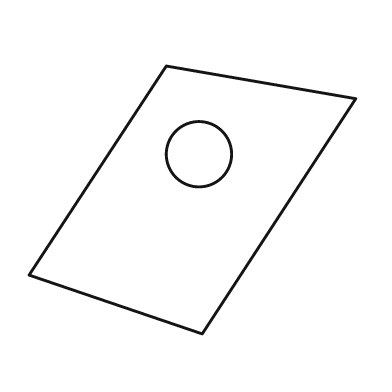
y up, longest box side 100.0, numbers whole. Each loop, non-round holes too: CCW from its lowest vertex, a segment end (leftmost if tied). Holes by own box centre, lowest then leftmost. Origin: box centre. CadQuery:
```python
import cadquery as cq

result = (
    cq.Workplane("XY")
    .moveTo(3.0, -41.0)
    .lineTo(50.0, 31.0)
    .lineTo(-8.0, 41.0)
    .lineTo(-50.0, -23.0)
    .close()
    .moveTo(2.0, 14.0)
    .circle(10.0)
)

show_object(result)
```